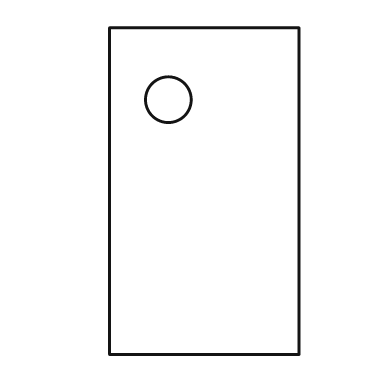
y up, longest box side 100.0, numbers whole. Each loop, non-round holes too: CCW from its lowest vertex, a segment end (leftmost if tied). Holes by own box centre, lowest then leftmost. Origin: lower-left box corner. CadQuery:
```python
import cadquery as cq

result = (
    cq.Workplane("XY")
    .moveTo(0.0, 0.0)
    .lineTo(58.0, 0.0)
    .lineTo(58.0, 100.0)
    .lineTo(0.0, 100.0)
    .close()
    .moveTo(18.0, 78.0)
    .circle(7.0)
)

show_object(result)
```